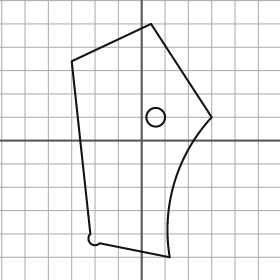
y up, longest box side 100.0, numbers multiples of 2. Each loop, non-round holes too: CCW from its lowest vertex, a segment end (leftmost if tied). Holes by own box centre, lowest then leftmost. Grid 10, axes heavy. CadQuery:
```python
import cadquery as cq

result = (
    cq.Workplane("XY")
    .moveTo(12.0, -50.0)
    .threePointArc((14.0, -18.0), (30.0, 10.0))
    .lineTo(4.0, 50.0)
    .lineTo(-30.0, 34.0)
    .lineTo(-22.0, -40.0)
    .threePointArc((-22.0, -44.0), (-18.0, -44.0))
    .close()
    .moveTo(6.0, 10.0)
    .circle(4.0)
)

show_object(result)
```